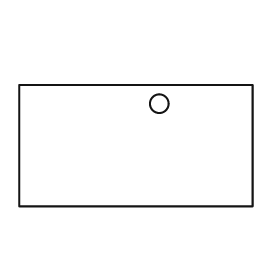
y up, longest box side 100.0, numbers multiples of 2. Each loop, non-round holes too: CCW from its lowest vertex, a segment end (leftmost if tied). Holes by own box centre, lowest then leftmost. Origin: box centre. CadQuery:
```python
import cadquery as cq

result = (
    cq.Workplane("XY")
    .moveTo(-50.0, -26.0)
    .lineTo(50.0, -26.0)
    .lineTo(50.0, 26.0)
    .lineTo(-50.0, 26.0)
    .close()
    .moveTo(10.0, 18.0)
    .circle(4.0)
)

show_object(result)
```